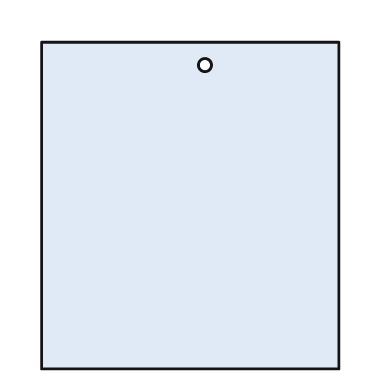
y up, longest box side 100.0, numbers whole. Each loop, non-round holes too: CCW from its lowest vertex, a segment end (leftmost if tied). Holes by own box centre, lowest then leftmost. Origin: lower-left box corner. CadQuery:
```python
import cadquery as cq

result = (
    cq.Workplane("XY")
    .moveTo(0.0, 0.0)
    .lineTo(91.0, 0.0)
    .lineTo(91.0, 100.0)
    .lineTo(0.0, 100.0)
    .close()
    .moveTo(50.0, 93.0)
    .circle(2.0)
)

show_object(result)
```